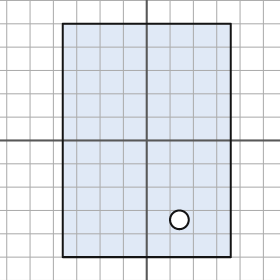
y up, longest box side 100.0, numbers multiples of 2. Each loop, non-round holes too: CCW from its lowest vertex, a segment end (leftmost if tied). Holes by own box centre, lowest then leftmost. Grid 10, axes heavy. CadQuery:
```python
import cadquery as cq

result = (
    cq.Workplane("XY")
    .moveTo(-36.0, -50.0)
    .lineTo(36.0, -50.0)
    .lineTo(36.0, 50.0)
    .lineTo(-36.0, 50.0)
    .close()
    .moveTo(14.0, -34.0)
    .circle(4.0)
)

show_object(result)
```